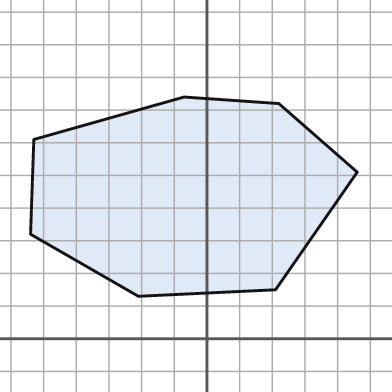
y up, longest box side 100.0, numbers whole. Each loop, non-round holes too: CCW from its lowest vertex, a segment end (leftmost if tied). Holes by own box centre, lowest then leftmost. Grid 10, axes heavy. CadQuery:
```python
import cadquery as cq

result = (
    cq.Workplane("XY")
    .moveTo(-21.0, 13.0)
    .lineTo(21.0, 15.0)
    .lineTo(46.0, 51.0)
    .lineTo(22.0, 72.0)
    .lineTo(-7.0, 74.0)
    .lineTo(-53.0, 61.0)
    .lineTo(-54.0, 32.0)
    .close()
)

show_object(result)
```